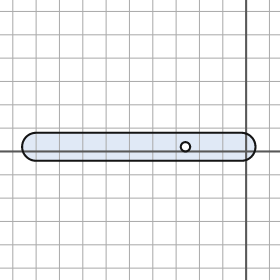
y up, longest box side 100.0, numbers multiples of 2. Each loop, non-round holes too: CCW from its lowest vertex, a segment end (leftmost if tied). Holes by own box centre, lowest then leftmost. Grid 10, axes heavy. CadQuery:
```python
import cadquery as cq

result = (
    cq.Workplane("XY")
    .moveTo(-90.0, -4.0)
    .lineTo(-2.0, -4.0)
    .threePointArc((4.0, 2.0), (-2.0, 8.0))
    .lineTo(-90.0, 8.0)
    .threePointArc((-96.0, 2.0), (-90.0, -4.0))
    .close()
    .moveTo(-26.0, 2.0)
    .circle(2.0)
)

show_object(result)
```